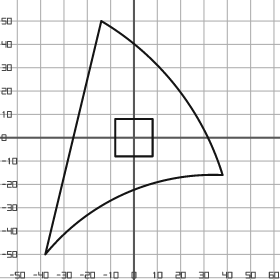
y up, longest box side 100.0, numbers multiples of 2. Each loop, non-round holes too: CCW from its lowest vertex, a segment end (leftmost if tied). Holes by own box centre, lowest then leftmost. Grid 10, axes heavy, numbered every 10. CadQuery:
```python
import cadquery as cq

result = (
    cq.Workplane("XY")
    .moveTo(-38.0, -50.0)
    .threePointArc((-4.0, -24.0), (38.0, -16.0))
    .threePointArc((18.0, 22.0), (-14.0, 50.0))
    .close()
    .moveTo(-8.0, -8.0)
    .lineTo(8.0, -8.0)
    .lineTo(8.0, 8.0)
    .lineTo(-8.0, 8.0)
    .close()
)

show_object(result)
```